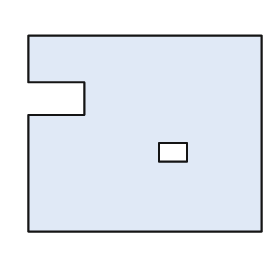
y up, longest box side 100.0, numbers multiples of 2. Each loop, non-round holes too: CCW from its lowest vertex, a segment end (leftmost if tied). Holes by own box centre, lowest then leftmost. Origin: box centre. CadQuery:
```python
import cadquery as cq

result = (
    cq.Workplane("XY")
    .moveTo(-50.0, -42.0)
    .lineTo(50.0, -42.0)
    .lineTo(50.0, 42.0)
    .lineTo(-50.0, 42.0)
    .lineTo(-50.0, 22.0)
    .lineTo(-26.0, 22.0)
    .lineTo(-26.0, 8.0)
    .lineTo(-50.0, 8.0)
    .close()
    .moveTo(6.0, -12.0)
    .lineTo(18.0, -12.0)
    .lineTo(18.0, -4.0)
    .lineTo(6.0, -4.0)
    .close()
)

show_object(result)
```